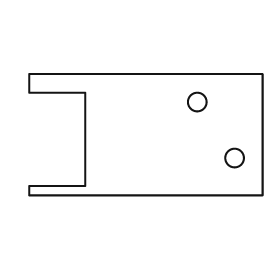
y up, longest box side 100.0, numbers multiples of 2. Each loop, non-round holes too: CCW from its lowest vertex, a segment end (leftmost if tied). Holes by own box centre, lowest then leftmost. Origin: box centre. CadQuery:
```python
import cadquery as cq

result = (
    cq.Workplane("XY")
    .moveTo(-50.0, -26.0)
    .lineTo(50.0, -26.0)
    .lineTo(50.0, 26.0)
    .lineTo(-50.0, 26.0)
    .lineTo(-50.0, 18.0)
    .lineTo(-26.0, 18.0)
    .lineTo(-26.0, -22.0)
    .lineTo(-50.0, -22.0)
    .close()
    .moveTo(38.0, -10.0)
    .circle(4.0)
    .moveTo(22.0, 14.0)
    .circle(4.0)
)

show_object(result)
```